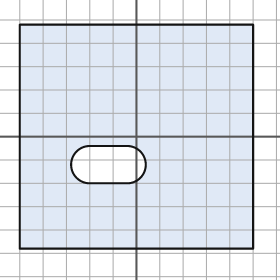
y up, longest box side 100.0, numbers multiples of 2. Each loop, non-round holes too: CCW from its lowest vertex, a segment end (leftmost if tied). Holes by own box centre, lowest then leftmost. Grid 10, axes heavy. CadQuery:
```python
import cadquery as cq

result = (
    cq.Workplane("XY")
    .moveTo(-50.0, -48.0)
    .lineTo(50.0, -48.0)
    .lineTo(50.0, 48.0)
    .lineTo(-50.0, 48.0)
    .close()
    .moveTo(-20.0, -20.0)
    .lineTo(-4.0, -20.0)
    .threePointArc((4.0, -12.0), (-4.0, -4.0))
    .lineTo(-20.0, -4.0)
    .threePointArc((-28.0, -12.0), (-20.0, -20.0))
    .close()
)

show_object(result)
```